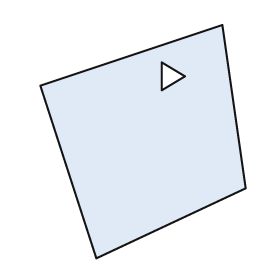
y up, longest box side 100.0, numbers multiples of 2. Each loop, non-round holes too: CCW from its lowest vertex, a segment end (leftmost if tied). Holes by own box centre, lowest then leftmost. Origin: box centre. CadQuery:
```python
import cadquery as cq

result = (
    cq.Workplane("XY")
    .moveTo(-20.0, -50.0)
    .lineTo(44.0, -20.0)
    .lineTo(34.0, 50.0)
    .lineTo(-44.0, 24.0)
    .close()
    .moveTo(8.0, 22.0)
    .lineTo(18.0, 28.0)
    .lineTo(8.0, 34.0)
    .close()
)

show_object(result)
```